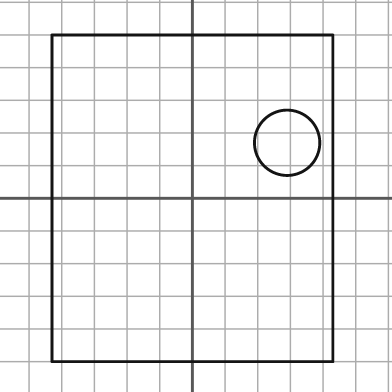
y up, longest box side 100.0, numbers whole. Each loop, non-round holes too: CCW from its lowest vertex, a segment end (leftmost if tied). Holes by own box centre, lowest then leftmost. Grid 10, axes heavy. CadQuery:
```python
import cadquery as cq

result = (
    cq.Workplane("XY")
    .moveTo(-43.0, -50.0)
    .lineTo(43.0, -50.0)
    .lineTo(43.0, 50.0)
    .lineTo(-43.0, 50.0)
    .close()
    .moveTo(29.0, 17.0)
    .circle(10.0)
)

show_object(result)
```